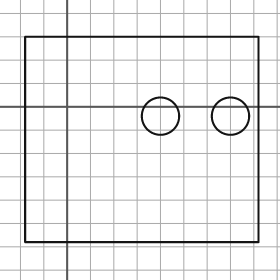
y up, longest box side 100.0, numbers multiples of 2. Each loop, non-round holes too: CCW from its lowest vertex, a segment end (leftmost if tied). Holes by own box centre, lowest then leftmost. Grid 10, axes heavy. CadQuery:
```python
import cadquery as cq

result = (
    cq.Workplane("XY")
    .moveTo(-18.0, -58.0)
    .lineTo(82.0, -58.0)
    .lineTo(82.0, 30.0)
    .lineTo(-18.0, 30.0)
    .close()
    .moveTo(40.0, -4.0)
    .circle(8.0)
    .moveTo(70.0, -4.0)
    .circle(8.0)
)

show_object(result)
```